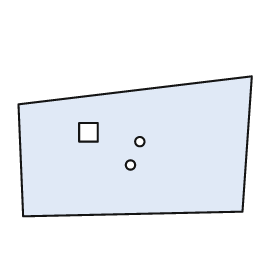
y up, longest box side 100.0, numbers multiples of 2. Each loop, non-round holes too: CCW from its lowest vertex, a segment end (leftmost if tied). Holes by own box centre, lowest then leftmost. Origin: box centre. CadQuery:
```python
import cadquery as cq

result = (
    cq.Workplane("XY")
    .moveTo(-48.0, -30.0)
    .lineTo(46.0, -28.0)
    .lineTo(50.0, 30.0)
    .lineTo(-50.0, 18.0)
    .close()
    .moveTo(-2.0, -8.0)
    .circle(2.0)
    .moveTo(2.0, 2.0)
    .circle(2.0)
    .moveTo(-24.0, 2.0)
    .lineTo(-16.0, 2.0)
    .lineTo(-16.0, 10.0)
    .lineTo(-24.0, 10.0)
    .close()
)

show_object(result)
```